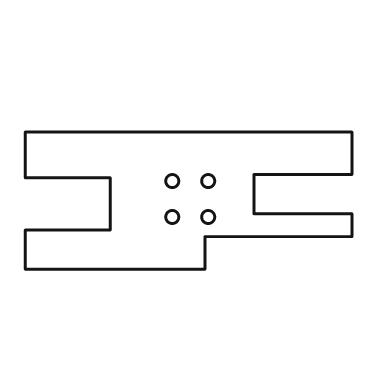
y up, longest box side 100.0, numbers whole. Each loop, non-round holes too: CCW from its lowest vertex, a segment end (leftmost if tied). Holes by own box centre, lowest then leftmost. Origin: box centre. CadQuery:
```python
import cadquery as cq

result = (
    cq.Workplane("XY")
    .moveTo(-50.0, -21.0)
    .lineTo(5.0, -21.0)
    .lineTo(5.0, -11.0)
    .lineTo(50.0, -11.0)
    .lineTo(50.0, -4.0)
    .lineTo(20.0, -4.0)
    .lineTo(20.0, 8.0)
    .lineTo(50.0, 8.0)
    .lineTo(50.0, 21.0)
    .lineTo(-50.0, 21.0)
    .lineTo(-50.0, 7.0)
    .lineTo(-24.0, 7.0)
    .lineTo(-24.0, -9.0)
    .lineTo(-50.0, -9.0)
    .close()
    .moveTo(-5.0, -5.0)
    .circle(2.0)
    .moveTo(6.0, -5.0)
    .circle(2.0)
    .moveTo(-5.0, 6.0)
    .circle(2.0)
    .moveTo(6.0, 6.0)
    .circle(2.0)
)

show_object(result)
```